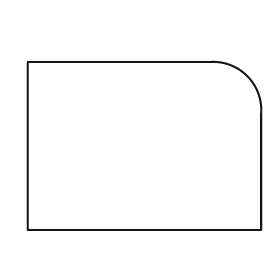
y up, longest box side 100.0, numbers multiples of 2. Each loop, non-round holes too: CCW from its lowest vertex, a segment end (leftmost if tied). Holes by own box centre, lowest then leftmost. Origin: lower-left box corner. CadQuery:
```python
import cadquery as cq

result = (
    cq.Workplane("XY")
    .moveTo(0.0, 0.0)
    .lineTo(100.0, 0.0)
    .lineTo(100.0, 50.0)
    .threePointArc((94.0, 66.0), (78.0, 72.0))
    .lineTo(0.0, 72.0)
    .close()
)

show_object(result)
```